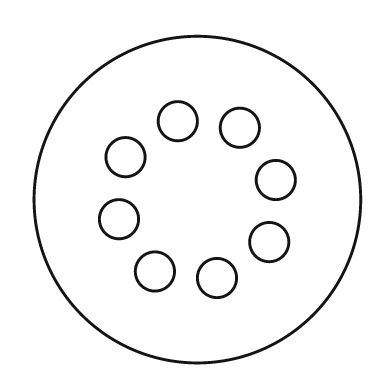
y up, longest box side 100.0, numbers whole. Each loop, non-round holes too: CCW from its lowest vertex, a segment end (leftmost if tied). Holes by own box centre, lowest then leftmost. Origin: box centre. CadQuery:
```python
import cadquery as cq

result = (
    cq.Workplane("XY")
    .moveTo(0.0, 0.0)
    .circle(50.0)
    .moveTo(6.0, -24.0)
    .circle(6.0)
    .moveTo(-13.0, -22.0)
    .circle(6.0)
    .moveTo(22.0, -13.0)
    .circle(6.0)
    .moveTo(-24.0, -6.0)
    .circle(6.0)
    .moveTo(24.0, 6.0)
    .circle(6.0)
    .moveTo(-22.0, 13.0)
    .circle(6.0)
    .moveTo(13.0, 22.0)
    .circle(6.0)
    .moveTo(-6.0, 24.0)
    .circle(6.0)
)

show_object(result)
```